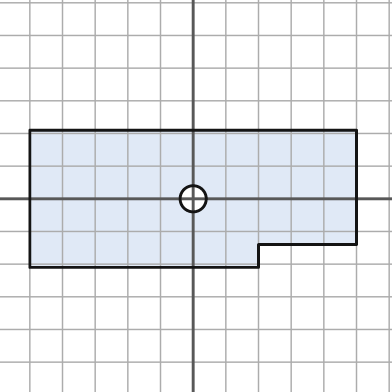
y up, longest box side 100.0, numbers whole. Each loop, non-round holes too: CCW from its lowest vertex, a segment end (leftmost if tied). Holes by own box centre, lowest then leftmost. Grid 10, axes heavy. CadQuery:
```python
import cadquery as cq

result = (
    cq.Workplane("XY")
    .moveTo(-50.0, -21.0)
    .lineTo(20.0, -21.0)
    .lineTo(20.0, -14.0)
    .lineTo(50.0, -14.0)
    .lineTo(50.0, 21.0)
    .lineTo(-50.0, 21.0)
    .close()
    .moveTo(0.0, 0.0)
    .circle(4.0)
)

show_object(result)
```